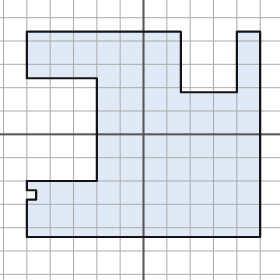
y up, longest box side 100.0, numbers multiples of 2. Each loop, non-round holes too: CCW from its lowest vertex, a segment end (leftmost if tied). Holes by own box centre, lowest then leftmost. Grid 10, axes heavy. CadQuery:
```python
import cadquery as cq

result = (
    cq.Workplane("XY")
    .moveTo(-50.0, -44.0)
    .lineTo(50.0, -44.0)
    .lineTo(50.0, 44.0)
    .lineTo(40.0, 44.0)
    .lineTo(40.0, 18.0)
    .lineTo(16.0, 18.0)
    .lineTo(16.0, 44.0)
    .lineTo(-50.0, 44.0)
    .lineTo(-50.0, 24.0)
    .lineTo(-20.0, 24.0)
    .lineTo(-20.0, -20.0)
    .lineTo(-50.0, -20.0)
    .lineTo(-50.0, -24.0)
    .lineTo(-46.0, -24.0)
    .lineTo(-46.0, -28.0)
    .lineTo(-50.0, -28.0)
    .close()
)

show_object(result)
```